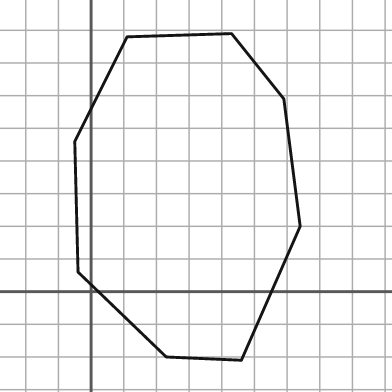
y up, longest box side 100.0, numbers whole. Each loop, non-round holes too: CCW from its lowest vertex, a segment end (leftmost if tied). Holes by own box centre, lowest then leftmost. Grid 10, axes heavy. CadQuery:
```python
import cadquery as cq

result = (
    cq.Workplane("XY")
    .moveTo(46.0, -21.0)
    .lineTo(64.0, 20.0)
    .lineTo(59.0, 59.0)
    .lineTo(43.0, 79.0)
    .lineTo(11.0, 78.0)
    .lineTo(-5.0, 46.0)
    .lineTo(-4.0, 6.0)
    .lineTo(23.0, -20.0)
    .close()
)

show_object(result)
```